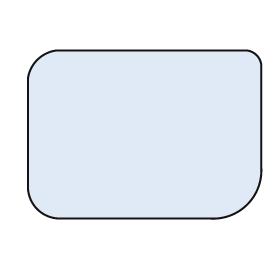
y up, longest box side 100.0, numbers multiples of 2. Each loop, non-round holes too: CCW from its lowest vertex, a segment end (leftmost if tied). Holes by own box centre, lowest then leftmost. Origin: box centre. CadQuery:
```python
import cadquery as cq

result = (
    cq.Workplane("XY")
    .moveTo(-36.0, -36.0)
    .lineTo(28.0, -36.0)
    .threePointArc((44.0, -30.0), (50.0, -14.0))
    .lineTo(50.0, 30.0)
    .threePointArc((48.0, 34.0), (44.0, 36.0))
    .lineTo(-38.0, 36.0)
    .threePointArc((-46.0, 32.0), (-50.0, 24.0))
    .lineTo(-50.0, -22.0)
    .threePointArc((-46.0, -32.0), (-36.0, -36.0))
    .close()
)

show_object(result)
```